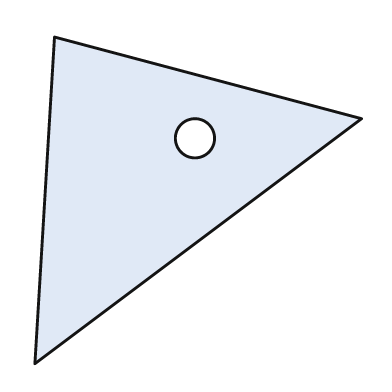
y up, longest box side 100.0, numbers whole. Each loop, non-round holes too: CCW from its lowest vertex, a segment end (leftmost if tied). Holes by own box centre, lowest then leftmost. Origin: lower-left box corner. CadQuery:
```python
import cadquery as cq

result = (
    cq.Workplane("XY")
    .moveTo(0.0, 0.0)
    .lineTo(100.0, 75.0)
    .lineTo(6.0, 100.0)
    .close()
    .moveTo(49.0, 69.0)
    .circle(6.0)
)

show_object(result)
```